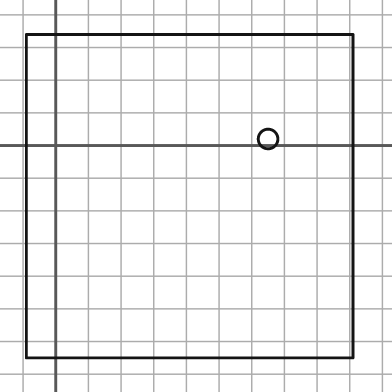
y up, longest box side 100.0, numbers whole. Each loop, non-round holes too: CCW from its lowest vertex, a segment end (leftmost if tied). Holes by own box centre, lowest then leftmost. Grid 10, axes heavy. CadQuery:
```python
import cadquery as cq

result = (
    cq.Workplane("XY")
    .moveTo(-9.0, -65.0)
    .lineTo(91.0, -65.0)
    .lineTo(91.0, 34.0)
    .lineTo(-9.0, 34.0)
    .close()
    .moveTo(65.0, 2.0)
    .circle(3.0)
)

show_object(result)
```